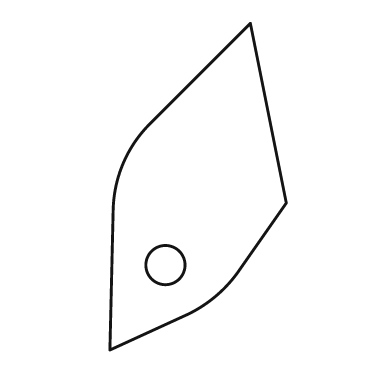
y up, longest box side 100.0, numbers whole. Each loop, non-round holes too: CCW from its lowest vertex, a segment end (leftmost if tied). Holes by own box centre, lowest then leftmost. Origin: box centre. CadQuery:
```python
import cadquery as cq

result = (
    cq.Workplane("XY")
    .moveTo(-27.0, -50.0)
    .lineTo(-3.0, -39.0)
    .threePointArc((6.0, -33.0), (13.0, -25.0))
    .lineTo(27.0, -5.0)
    .lineTo(16.0, 50.0)
    .lineTo(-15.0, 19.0)
    .threePointArc((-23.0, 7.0), (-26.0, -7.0))
    .close()
    .moveTo(-10.0, -24.0)
    .circle(6.0)
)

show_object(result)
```